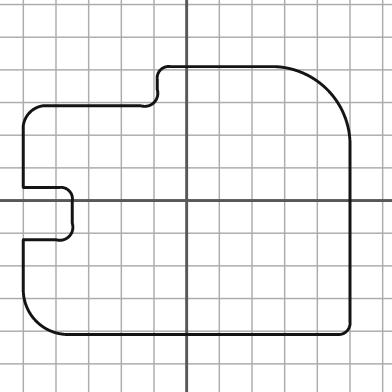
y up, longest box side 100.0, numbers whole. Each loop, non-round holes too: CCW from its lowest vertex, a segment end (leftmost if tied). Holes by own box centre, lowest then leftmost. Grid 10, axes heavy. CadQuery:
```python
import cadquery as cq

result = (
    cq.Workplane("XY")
    .moveTo(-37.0, -41.0)
    .lineTo(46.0, -41.0)
    .threePointArc((49.0, -40.0), (50.0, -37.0))
    .lineTo(50.0, 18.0)
    .threePointArc((43.0, 34.0), (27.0, 41.0))
    .lineTo(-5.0, 41.0)
    .threePointArc((-8.0, 40.0), (-9.0, 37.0))
    .lineTo(-9.0, 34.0)
    .threePointArc((-10.0, 30.0), (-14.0, 29.0))
    .lineTo(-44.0, 29.0)
    .threePointArc((-48.0, 27.0), (-50.0, 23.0))
    .lineTo(-50.0, 4.0)
    .lineTo(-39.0, 4.0)
    .threePointArc((-36.0, 3.0), (-35.0, 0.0))
    .lineTo(-35.0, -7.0)
    .threePointArc((-36.0, -11.0), (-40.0, -12.0))
    .lineTo(-50.0, -12.0)
    .lineTo(-50.0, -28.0)
    .threePointArc((-46.0, -37.0), (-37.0, -41.0))
    .close()
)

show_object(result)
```